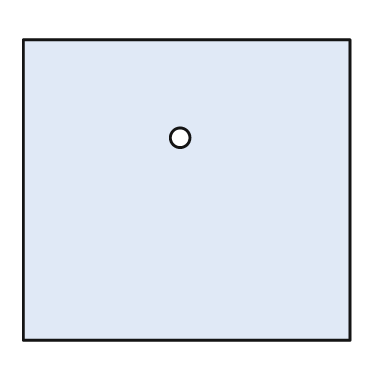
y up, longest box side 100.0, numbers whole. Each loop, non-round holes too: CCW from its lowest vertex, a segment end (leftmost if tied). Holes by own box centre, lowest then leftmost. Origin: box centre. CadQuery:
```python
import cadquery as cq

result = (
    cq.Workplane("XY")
    .moveTo(-50.0, -46.0)
    .lineTo(50.0, -46.0)
    .lineTo(50.0, 46.0)
    .lineTo(-50.0, 46.0)
    .close()
    .moveTo(-2.0, 16.0)
    .circle(3.0)
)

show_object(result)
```